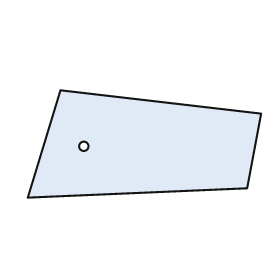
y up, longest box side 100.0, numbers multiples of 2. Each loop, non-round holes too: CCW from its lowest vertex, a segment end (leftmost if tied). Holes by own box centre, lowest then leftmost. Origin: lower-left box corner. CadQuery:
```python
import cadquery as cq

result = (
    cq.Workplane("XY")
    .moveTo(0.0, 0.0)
    .lineTo(94.0, 4.0)
    .lineTo(100.0, 36.0)
    .lineTo(14.0, 46.0)
    .close()
    .moveTo(24.0, 22.0)
    .circle(2.0)
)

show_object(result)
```